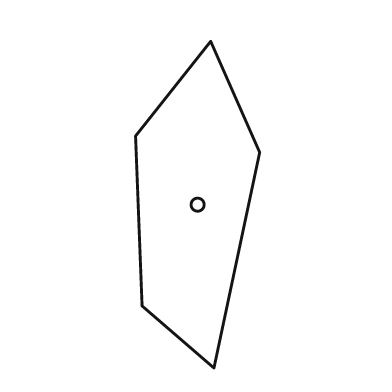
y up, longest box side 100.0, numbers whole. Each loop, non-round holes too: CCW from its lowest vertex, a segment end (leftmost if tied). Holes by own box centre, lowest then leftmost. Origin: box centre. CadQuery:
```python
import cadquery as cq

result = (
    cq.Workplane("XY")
    .moveTo(5.0, -50.0)
    .lineTo(19.0, 16.0)
    .lineTo(4.0, 50.0)
    .lineTo(-19.0, 21.0)
    .lineTo(-17.0, -31.0)
    .close()
    .moveTo(0.0, 0.0)
    .circle(2.0)
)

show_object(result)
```